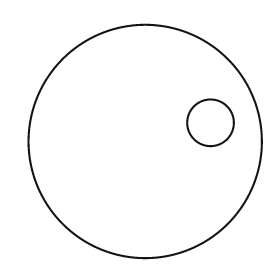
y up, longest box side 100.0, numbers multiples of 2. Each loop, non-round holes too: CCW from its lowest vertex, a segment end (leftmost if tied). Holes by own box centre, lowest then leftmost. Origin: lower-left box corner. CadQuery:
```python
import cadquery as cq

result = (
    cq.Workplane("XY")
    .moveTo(50.0, 50.0)
    .circle(50.0)
    .moveTo(78.0, 58.0)
    .circle(10.0)
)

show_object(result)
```